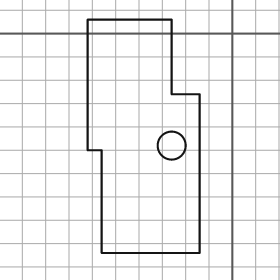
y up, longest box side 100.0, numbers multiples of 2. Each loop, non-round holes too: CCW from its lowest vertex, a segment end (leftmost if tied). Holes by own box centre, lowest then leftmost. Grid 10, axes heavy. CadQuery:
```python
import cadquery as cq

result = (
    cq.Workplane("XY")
    .moveTo(-56.0, -94.0)
    .lineTo(-14.0, -94.0)
    .lineTo(-14.0, -26.0)
    .lineTo(-26.0, -26.0)
    .lineTo(-26.0, 6.0)
    .lineTo(-62.0, 6.0)
    .lineTo(-62.0, -50.0)
    .lineTo(-56.0, -50.0)
    .close()
    .moveTo(-26.0, -48.0)
    .circle(6.0)
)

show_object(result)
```